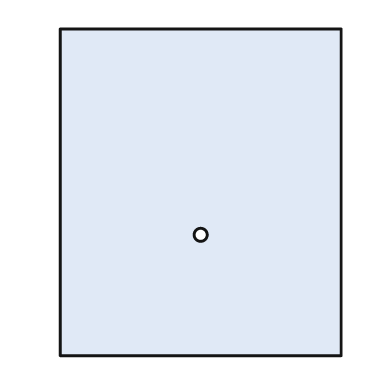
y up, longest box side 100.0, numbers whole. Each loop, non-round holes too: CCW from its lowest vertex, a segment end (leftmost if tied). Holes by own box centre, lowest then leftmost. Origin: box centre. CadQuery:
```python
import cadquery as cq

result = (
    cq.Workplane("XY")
    .moveTo(-43.0, -50.0)
    .lineTo(43.0, -50.0)
    .lineTo(43.0, 50.0)
    .lineTo(-43.0, 50.0)
    .close()
    .moveTo(0.0, -13.0)
    .circle(2.0)
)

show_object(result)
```